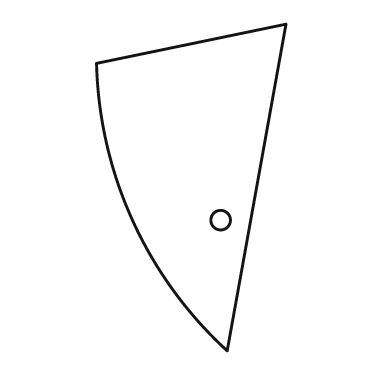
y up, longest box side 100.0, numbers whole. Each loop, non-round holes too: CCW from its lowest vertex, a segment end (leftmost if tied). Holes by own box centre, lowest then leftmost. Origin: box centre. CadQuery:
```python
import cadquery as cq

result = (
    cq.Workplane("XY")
    .moveTo(11.0, -50.0)
    .lineTo(29.0, 50.0)
    .lineTo(-29.0, 38.0)
    .threePointArc((-18.0, -10.0), (11.0, -50.0))
    .close()
    .moveTo(9.0, -10.0)
    .circle(3.0)
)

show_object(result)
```